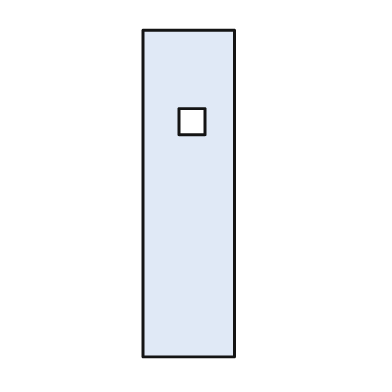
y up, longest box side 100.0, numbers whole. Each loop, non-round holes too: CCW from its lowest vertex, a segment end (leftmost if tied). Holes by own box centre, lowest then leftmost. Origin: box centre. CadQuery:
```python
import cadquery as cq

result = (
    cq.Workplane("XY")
    .moveTo(-14.0, -50.0)
    .lineTo(14.0, -50.0)
    .lineTo(14.0, 50.0)
    .lineTo(-14.0, 50.0)
    .close()
    .moveTo(-3.0, 18.0)
    .lineTo(5.0, 18.0)
    .lineTo(5.0, 26.0)
    .lineTo(-3.0, 26.0)
    .close()
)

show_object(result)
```